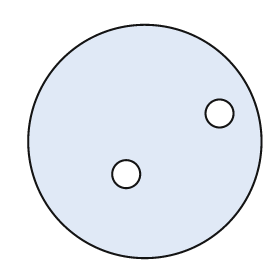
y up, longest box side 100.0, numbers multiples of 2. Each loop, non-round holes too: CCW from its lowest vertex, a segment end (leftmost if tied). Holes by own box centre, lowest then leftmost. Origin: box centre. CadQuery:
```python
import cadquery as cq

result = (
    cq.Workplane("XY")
    .moveTo(0.0, 0.0)
    .circle(50.0)
    .moveTo(-8.0, -14.0)
    .circle(6.0)
    .moveTo(32.0, 12.0)
    .circle(6.0)
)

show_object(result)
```